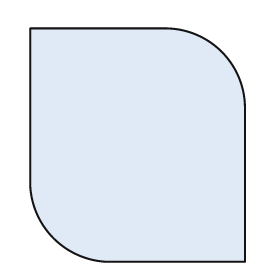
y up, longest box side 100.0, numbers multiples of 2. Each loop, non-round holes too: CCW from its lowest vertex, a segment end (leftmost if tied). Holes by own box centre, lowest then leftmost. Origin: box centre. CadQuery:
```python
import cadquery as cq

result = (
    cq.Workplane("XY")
    .moveTo(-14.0, -50.0)
    .lineTo(46.0, -50.0)
    .lineTo(46.0, 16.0)
    .threePointArc((36.0, 40.0), (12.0, 50.0))
    .lineTo(-46.0, 50.0)
    .lineTo(-46.0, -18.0)
    .threePointArc((-36.0, -40.0), (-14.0, -50.0))
    .close()
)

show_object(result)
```